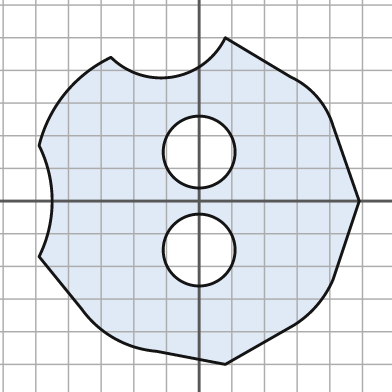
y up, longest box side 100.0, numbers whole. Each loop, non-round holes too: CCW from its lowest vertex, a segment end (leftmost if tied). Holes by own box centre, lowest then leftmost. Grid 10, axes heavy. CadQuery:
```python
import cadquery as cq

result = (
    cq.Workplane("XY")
    .moveTo(8.0, -50.0)
    .lineTo(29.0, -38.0)
    .threePointArc((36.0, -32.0), (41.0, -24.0))
    .lineTo(49.0, 0.0)
    .lineTo(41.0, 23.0)
    .threePointArc((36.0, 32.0), (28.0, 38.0))
    .lineTo(8.0, 50.0)
    .threePointArc((-8.0, 38.0), (-27.0, 44.0))
    .threePointArc((-41.0, 33.0), (-49.0, 17.0))
    .threePointArc((-45.0, 0.0), (-49.0, -17.0))
    .lineTo(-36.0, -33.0)
    .threePointArc((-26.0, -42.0), (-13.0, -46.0))
    .close()
    .moveTo(0.0, -15.0)
    .circle(11.0)
    .moveTo(0.0, 15.0)
    .circle(11.0)
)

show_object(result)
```